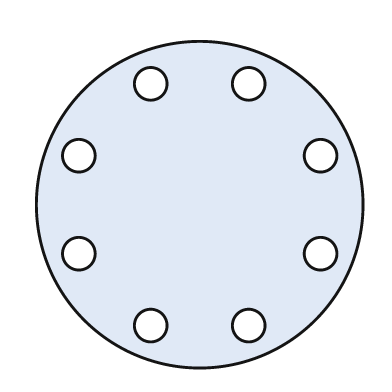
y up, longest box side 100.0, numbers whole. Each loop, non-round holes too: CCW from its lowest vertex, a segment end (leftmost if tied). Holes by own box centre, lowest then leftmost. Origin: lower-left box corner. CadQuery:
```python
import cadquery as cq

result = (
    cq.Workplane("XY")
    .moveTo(50.0, 50.0)
    .circle(50.0)
    .moveTo(35.0, 13.0)
    .circle(5.0)
    .moveTo(65.0, 13.0)
    .circle(5.0)
    .moveTo(13.0, 35.0)
    .circle(5.0)
    .moveTo(87.0, 35.0)
    .circle(5.0)
    .moveTo(13.0, 65.0)
    .circle(5.0)
    .moveTo(87.0, 65.0)
    .circle(5.0)
    .moveTo(35.0, 87.0)
    .circle(5.0)
    .moveTo(65.0, 87.0)
    .circle(5.0)
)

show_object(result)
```